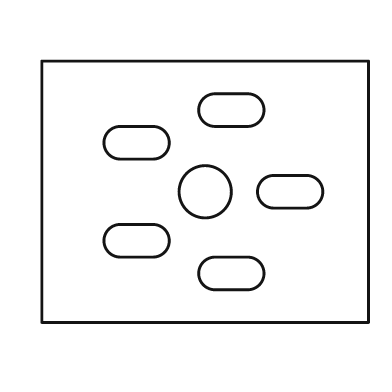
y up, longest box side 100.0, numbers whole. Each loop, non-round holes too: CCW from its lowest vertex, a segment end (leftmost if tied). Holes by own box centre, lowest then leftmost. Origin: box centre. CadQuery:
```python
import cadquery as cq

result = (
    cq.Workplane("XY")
    .moveTo(-50.0, -40.0)
    .lineTo(50.0, -40.0)
    .lineTo(50.0, 40.0)
    .lineTo(-50.0, 40.0)
    .close()
    .moveTo(3.0, -30.0)
    .lineTo(13.0, -30.0)
    .threePointArc((18.0, -25.0), (13.0, -20.0))
    .lineTo(3.0, -20.0)
    .threePointArc((-2.0, -25.0), (3.0, -30.0))
    .close()
    .moveTo(-26.0, -20.0)
    .lineTo(-16.0, -20.0)
    .threePointArc((-11.0, -15.0), (-16.0, -10.0))
    .lineTo(-26.0, -10.0)
    .threePointArc((-31.0, -15.0), (-26.0, -20.0))
    .close()
    .moveTo(0.0, 0.0)
    .circle(8.0)
    .moveTo(21.0, -5.0)
    .lineTo(31.0, -5.0)
    .threePointArc((36.0, 0.0), (31.0, 5.0))
    .lineTo(21.0, 5.0)
    .threePointArc((16.0, 0.0), (21.0, -5.0))
    .close()
    .moveTo(-26.0, 10.0)
    .lineTo(-16.0, 10.0)
    .threePointArc((-11.0, 15.0), (-16.0, 20.0))
    .lineTo(-26.0, 20.0)
    .threePointArc((-31.0, 15.0), (-26.0, 10.0))
    .close()
    .moveTo(3.0, 20.0)
    .lineTo(13.0, 20.0)
    .threePointArc((18.0, 25.0), (13.0, 30.0))
    .lineTo(3.0, 30.0)
    .threePointArc((-2.0, 25.0), (3.0, 20.0))
    .close()
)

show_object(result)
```